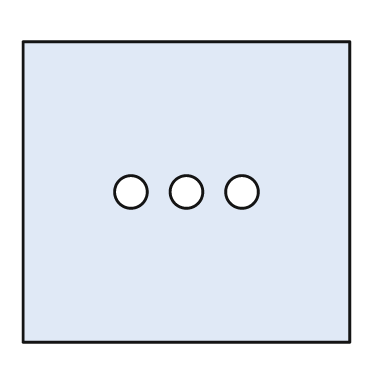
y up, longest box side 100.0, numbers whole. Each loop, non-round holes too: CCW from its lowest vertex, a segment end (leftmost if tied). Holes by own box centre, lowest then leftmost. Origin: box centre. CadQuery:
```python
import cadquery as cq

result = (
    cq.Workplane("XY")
    .moveTo(-50.0, -46.0)
    .lineTo(50.0, -46.0)
    .lineTo(50.0, 46.0)
    .lineTo(-50.0, 46.0)
    .close()
    .moveTo(-17.0, 0.0)
    .circle(5.0)
    .moveTo(0.0, 0.0)
    .circle(5.0)
    .moveTo(17.0, 0.0)
    .circle(5.0)
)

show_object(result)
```